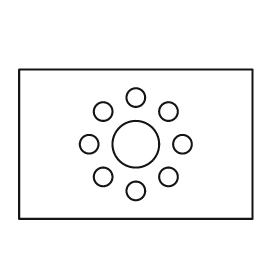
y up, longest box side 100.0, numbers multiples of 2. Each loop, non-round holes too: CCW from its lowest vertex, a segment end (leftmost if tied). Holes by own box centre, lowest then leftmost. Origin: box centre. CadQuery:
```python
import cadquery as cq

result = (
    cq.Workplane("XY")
    .moveTo(-50.0, -32.0)
    .lineTo(50.0, -32.0)
    .lineTo(50.0, 32.0)
    .lineTo(-50.0, 32.0)
    .close()
    .moveTo(0.0, -20.0)
    .circle(4.0)
    .moveTo(-14.0, -14.0)
    .circle(4.0)
    .moveTo(14.0, -14.0)
    .circle(4.0)
    .moveTo(-20.0, 0.0)
    .circle(4.0)
    .moveTo(0.0, 0.0)
    .circle(10.0)
    .moveTo(20.0, 0.0)
    .circle(4.0)
    .moveTo(-14.0, 14.0)
    .circle(4.0)
    .moveTo(14.0, 14.0)
    .circle(4.0)
    .moveTo(0.0, 20.0)
    .circle(4.0)
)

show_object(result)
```